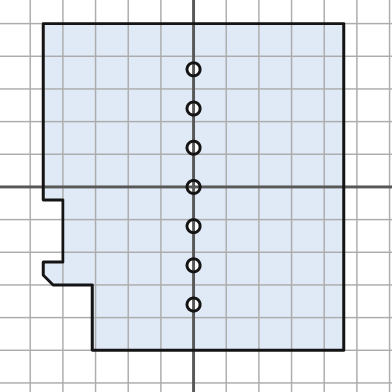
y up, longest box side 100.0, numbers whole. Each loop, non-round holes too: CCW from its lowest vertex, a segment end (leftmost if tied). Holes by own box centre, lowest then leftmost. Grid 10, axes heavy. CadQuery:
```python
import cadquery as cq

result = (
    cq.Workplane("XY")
    .moveTo(-31.0, -50.0)
    .lineTo(46.0, -50.0)
    .lineTo(46.0, 50.0)
    .lineTo(-46.0, 50.0)
    .lineTo(-46.0, -4.0)
    .lineTo(-40.0, -4.0)
    .lineTo(-40.0, -23.0)
    .lineTo(-46.0, -23.0)
    .lineTo(-46.0, -27.0)
    .lineTo(-43.0, -30.0)
    .lineTo(-31.0, -30.0)
    .close()
    .moveTo(0.0, -36.0)
    .circle(2.0)
    .moveTo(0.0, -24.0)
    .circle(2.0)
    .moveTo(0.0, -12.0)
    .circle(2.0)
    .moveTo(0.0, 0.0)
    .circle(2.0)
    .moveTo(0.0, 12.0)
    .circle(2.0)
    .moveTo(0.0, 24.0)
    .circle(2.0)
    .moveTo(0.0, 36.0)
    .circle(2.0)
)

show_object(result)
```